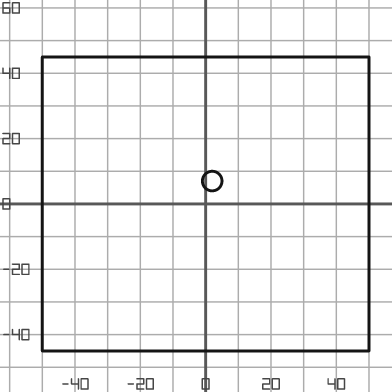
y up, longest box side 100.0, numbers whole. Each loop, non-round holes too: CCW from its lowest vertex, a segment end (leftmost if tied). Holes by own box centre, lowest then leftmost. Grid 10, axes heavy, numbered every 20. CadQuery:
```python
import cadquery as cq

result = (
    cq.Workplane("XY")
    .moveTo(-50.0, -45.0)
    .lineTo(50.0, -45.0)
    .lineTo(50.0, 45.0)
    .lineTo(-50.0, 45.0)
    .close()
    .moveTo(2.0, 7.0)
    .circle(3.0)
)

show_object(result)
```